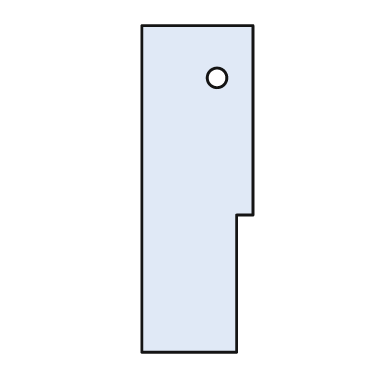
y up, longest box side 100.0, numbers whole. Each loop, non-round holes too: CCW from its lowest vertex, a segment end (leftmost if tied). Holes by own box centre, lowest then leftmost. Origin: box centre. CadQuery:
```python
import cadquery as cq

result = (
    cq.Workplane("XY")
    .moveTo(-17.0, -50.0)
    .lineTo(12.0, -50.0)
    .lineTo(12.0, -8.0)
    .lineTo(17.0, -8.0)
    .lineTo(17.0, 50.0)
    .lineTo(-17.0, 50.0)
    .close()
    .moveTo(6.0, 34.0)
    .circle(3.0)
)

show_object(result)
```